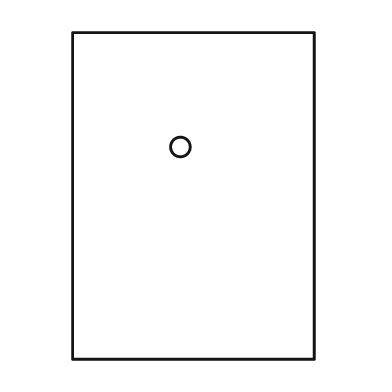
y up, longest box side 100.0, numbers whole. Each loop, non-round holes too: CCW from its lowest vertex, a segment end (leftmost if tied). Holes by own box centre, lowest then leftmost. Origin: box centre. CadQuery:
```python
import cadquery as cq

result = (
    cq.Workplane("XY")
    .moveTo(-37.0, -50.0)
    .lineTo(37.0, -50.0)
    .lineTo(37.0, 50.0)
    .lineTo(-37.0, 50.0)
    .close()
    .moveTo(-4.0, 15.0)
    .circle(3.0)
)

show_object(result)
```